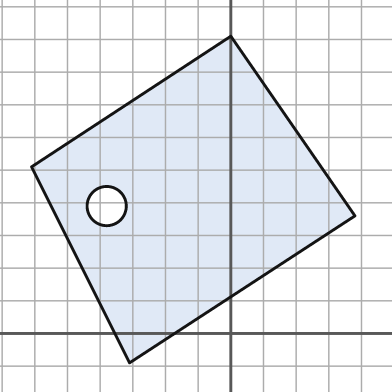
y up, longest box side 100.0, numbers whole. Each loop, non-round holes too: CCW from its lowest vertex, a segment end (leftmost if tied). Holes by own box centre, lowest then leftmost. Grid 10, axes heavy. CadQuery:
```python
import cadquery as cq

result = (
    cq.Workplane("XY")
    .moveTo(-31.0, -9.0)
    .lineTo(38.0, 36.0)
    .lineTo(0.0, 91.0)
    .lineTo(-61.0, 51.0)
    .close()
    .moveTo(-38.0, 39.0)
    .circle(6.0)
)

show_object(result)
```